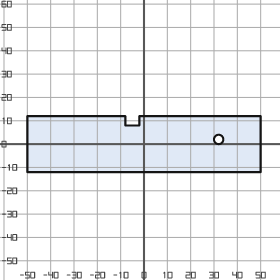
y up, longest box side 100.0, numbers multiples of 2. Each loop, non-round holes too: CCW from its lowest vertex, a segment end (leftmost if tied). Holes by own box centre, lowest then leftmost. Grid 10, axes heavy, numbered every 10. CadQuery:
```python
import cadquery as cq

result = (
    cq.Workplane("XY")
    .moveTo(-50.0, -12.0)
    .lineTo(50.0, -12.0)
    .lineTo(50.0, 12.0)
    .lineTo(-2.0, 12.0)
    .lineTo(-2.0, 8.0)
    .lineTo(-8.0, 8.0)
    .lineTo(-8.0, 12.0)
    .lineTo(-50.0, 12.0)
    .close()
    .moveTo(32.0, 2.0)
    .circle(2.0)
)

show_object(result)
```